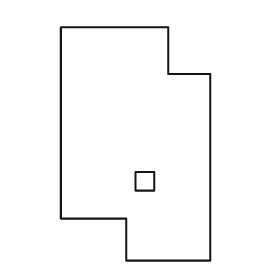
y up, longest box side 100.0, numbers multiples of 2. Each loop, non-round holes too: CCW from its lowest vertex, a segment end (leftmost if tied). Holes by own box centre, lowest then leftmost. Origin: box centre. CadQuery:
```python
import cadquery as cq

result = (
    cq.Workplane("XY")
    .moveTo(-4.0, -50.0)
    .lineTo(32.0, -50.0)
    .lineTo(32.0, 30.0)
    .lineTo(14.0, 30.0)
    .lineTo(14.0, 50.0)
    .lineTo(-32.0, 50.0)
    .lineTo(-32.0, -32.0)
    .lineTo(-4.0, -32.0)
    .close()
    .moveTo(0.0, -20.0)
    .lineTo(8.0, -20.0)
    .lineTo(8.0, -12.0)
    .lineTo(0.0, -12.0)
    .close()
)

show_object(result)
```